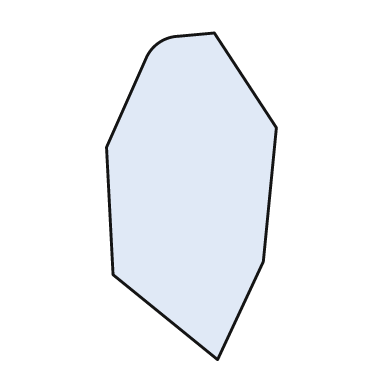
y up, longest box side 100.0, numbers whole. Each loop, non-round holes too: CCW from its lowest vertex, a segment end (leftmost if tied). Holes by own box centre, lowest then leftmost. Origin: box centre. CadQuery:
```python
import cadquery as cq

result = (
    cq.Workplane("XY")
    .moveTo(8.0, -50.0)
    .lineTo(22.0, -20.0)
    .lineTo(26.0, 21.0)
    .lineTo(7.0, 50.0)
    .lineTo(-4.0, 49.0)
    .threePointArc((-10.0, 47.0), (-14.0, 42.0))
    .lineTo(-26.0, 15.0)
    .lineTo(-24.0, -24.0)
    .close()
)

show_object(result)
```